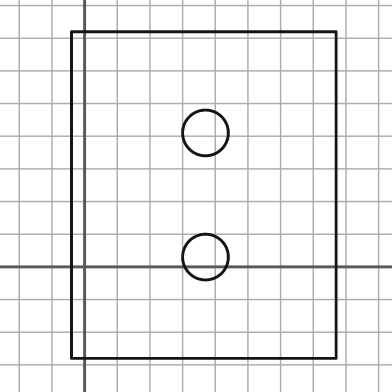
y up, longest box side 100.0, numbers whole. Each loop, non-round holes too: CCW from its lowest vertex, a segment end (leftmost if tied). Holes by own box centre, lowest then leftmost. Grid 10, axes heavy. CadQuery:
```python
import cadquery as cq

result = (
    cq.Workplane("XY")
    .moveTo(-4.0, -28.0)
    .lineTo(77.0, -28.0)
    .lineTo(77.0, 72.0)
    .lineTo(-4.0, 72.0)
    .close()
    .moveTo(37.0, 3.0)
    .circle(7.0)
    .moveTo(37.0, 41.0)
    .circle(7.0)
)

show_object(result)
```